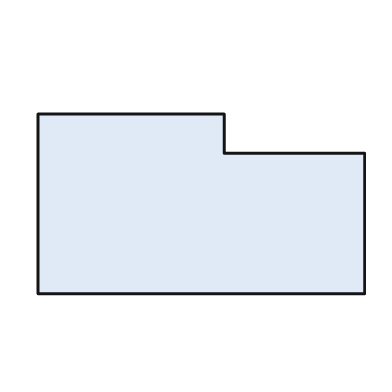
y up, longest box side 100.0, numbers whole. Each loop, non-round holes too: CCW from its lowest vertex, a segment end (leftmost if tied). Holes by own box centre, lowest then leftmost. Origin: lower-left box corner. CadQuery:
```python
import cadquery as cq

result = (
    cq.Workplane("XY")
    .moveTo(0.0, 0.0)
    .lineTo(100.0, 0.0)
    .lineTo(100.0, 43.0)
    .lineTo(57.0, 43.0)
    .lineTo(57.0, 55.0)
    .lineTo(0.0, 55.0)
    .close()
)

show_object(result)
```